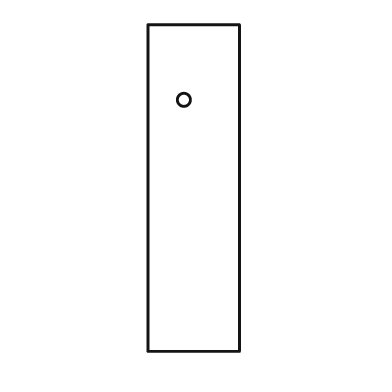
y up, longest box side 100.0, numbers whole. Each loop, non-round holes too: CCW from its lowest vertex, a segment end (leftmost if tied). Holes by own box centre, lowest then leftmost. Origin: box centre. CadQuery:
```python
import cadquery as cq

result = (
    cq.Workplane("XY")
    .moveTo(-14.0, -50.0)
    .lineTo(14.0, -50.0)
    .lineTo(14.0, 50.0)
    .lineTo(-14.0, 50.0)
    .close()
    .moveTo(-3.0, 27.0)
    .circle(2.0)
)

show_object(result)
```